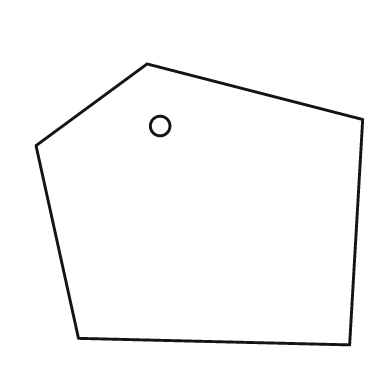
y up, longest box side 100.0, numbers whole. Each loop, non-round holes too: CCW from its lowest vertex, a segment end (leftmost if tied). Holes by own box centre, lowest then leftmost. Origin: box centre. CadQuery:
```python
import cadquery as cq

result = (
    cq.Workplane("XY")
    .moveTo(46.0, -43.0)
    .lineTo(50.0, 26.0)
    .lineTo(-16.0, 43.0)
    .lineTo(-50.0, 18.0)
    .lineTo(-37.0, -41.0)
    .close()
    .moveTo(-12.0, 24.0)
    .circle(3.0)
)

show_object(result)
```